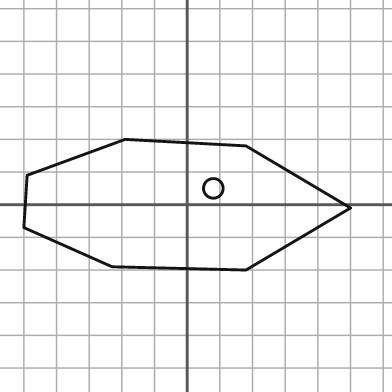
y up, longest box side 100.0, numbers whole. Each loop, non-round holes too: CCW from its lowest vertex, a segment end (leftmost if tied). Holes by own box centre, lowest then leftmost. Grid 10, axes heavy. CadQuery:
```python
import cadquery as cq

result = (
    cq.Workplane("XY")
    .moveTo(18.0, -20.0)
    .lineTo(50.0, -1.0)
    .lineTo(18.0, 18.0)
    .lineTo(-19.0, 20.0)
    .lineTo(-49.0, 9.0)
    .lineTo(-50.0, -7.0)
    .lineTo(-23.0, -19.0)
    .close()
    .moveTo(8.0, 5.0)
    .circle(3.0)
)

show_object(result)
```